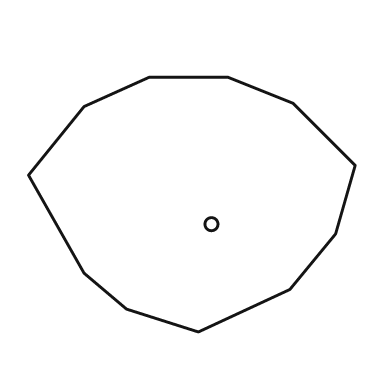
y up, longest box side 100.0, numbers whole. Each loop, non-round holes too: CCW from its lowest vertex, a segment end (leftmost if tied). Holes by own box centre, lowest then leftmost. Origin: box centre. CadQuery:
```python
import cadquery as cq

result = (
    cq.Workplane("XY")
    .moveTo(2.0, -39.0)
    .lineTo(30.0, -26.0)
    .lineTo(44.0, -9.0)
    .lineTo(50.0, 12.0)
    .lineTo(31.0, 31.0)
    .lineTo(11.0, 39.0)
    .lineTo(-13.0, 39.0)
    .lineTo(-33.0, 30.0)
    .lineTo(-50.0, 9.0)
    .lineTo(-33.0, -21.0)
    .lineTo(-20.0, -32.0)
    .close()
    .moveTo(6.0, -6.0)
    .circle(2.0)
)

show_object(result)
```